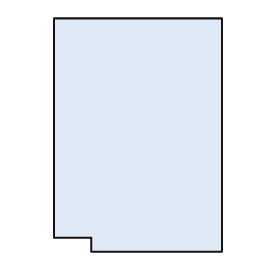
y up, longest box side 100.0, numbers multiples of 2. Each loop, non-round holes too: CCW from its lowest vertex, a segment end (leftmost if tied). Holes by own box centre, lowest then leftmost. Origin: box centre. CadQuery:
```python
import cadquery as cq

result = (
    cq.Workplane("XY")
    .moveTo(-20.0, -50.0)
    .lineTo(36.0, -50.0)
    .lineTo(36.0, 50.0)
    .lineTo(-36.0, 50.0)
    .lineTo(-36.0, -44.0)
    .lineTo(-20.0, -44.0)
    .close()
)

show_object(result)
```